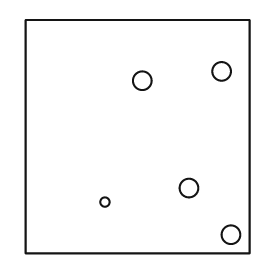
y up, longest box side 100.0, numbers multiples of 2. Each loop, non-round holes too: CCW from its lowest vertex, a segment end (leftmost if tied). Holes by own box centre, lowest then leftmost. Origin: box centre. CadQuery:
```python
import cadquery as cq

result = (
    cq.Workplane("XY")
    .moveTo(-48.0, -50.0)
    .lineTo(48.0, -50.0)
    .lineTo(48.0, 50.0)
    .lineTo(-48.0, 50.0)
    .close()
    .moveTo(40.0, -42.0)
    .circle(4.0)
    .moveTo(-14.0, -28.0)
    .circle(2.0)
    .moveTo(22.0, -22.0)
    .circle(4.0)
    .moveTo(2.0, 24.0)
    .circle(4.0)
    .moveTo(36.0, 28.0)
    .circle(4.0)
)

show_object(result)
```